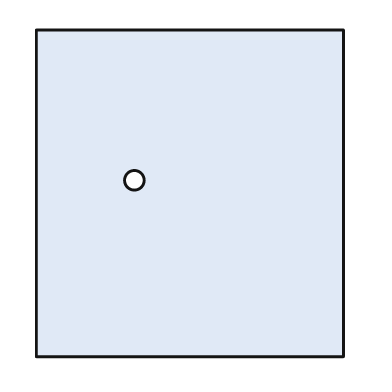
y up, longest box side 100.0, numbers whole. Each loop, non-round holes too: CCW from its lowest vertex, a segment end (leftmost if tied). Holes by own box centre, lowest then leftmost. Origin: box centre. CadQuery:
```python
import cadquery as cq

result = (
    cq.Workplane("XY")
    .moveTo(-47.0, -50.0)
    .lineTo(47.0, -50.0)
    .lineTo(47.0, 50.0)
    .lineTo(-47.0, 50.0)
    .close()
    .moveTo(-17.0, 4.0)
    .circle(3.0)
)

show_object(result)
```